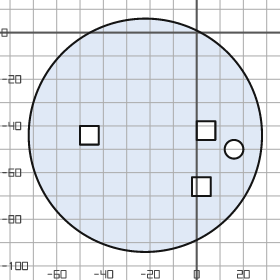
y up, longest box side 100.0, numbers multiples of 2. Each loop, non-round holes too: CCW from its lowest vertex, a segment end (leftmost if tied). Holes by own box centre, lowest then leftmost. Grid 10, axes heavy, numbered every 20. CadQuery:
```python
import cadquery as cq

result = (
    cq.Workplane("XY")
    .moveTo(-22.0, -44.0)
    .circle(50.0)
    .moveTo(-2.0, -70.0)
    .lineTo(6.0, -70.0)
    .lineTo(6.0, -62.0)
    .lineTo(-2.0, -62.0)
    .close()
    .moveTo(16.0, -50.0)
    .circle(4.0)
    .moveTo(-50.0, -48.0)
    .lineTo(-42.0, -48.0)
    .lineTo(-42.0, -40.0)
    .lineTo(-50.0, -40.0)
    .close()
    .moveTo(0.0, -46.0)
    .lineTo(8.0, -46.0)
    .lineTo(8.0, -38.0)
    .lineTo(0.0, -38.0)
    .close()
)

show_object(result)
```